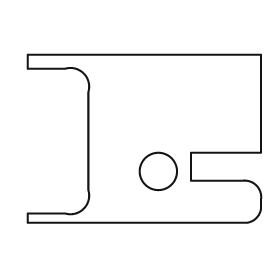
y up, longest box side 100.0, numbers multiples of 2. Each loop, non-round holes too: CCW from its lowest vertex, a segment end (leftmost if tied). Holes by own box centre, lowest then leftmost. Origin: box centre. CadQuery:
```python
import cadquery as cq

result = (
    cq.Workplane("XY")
    .moveTo(-50.0, -36.0)
    .lineTo(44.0, -36.0)
    .threePointArc((48.0, -34.0), (50.0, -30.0))
    .lineTo(50.0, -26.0)
    .threePointArc((48.0, -20.0), (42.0, -18.0))
    .lineTo(20.0, -18.0)
    .lineTo(20.0, -6.0)
    .lineTo(50.0, -6.0)
    .lineTo(50.0, 36.0)
    .lineTo(-50.0, 36.0)
    .lineTo(-50.0, 30.0)
    .lineTo(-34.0, 30.0)
    .threePointArc((-26.0, 28.0), (-24.0, 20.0))
    .lineTo(-24.0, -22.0)
    .threePointArc((-26.0, -30.0), (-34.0, -32.0))
    .lineTo(-50.0, -32.0)
    .close()
    .moveTo(6.0, -14.0)
    .circle(8.0)
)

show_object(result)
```